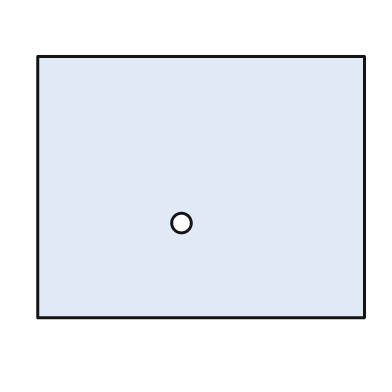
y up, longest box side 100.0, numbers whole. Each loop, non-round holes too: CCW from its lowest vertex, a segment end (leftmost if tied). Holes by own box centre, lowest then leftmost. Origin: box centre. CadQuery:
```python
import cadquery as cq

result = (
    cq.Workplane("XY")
    .moveTo(-50.0, -40.0)
    .lineTo(50.0, -40.0)
    .lineTo(50.0, 40.0)
    .lineTo(-50.0, 40.0)
    .close()
    .moveTo(-6.0, -11.0)
    .circle(3.0)
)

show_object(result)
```